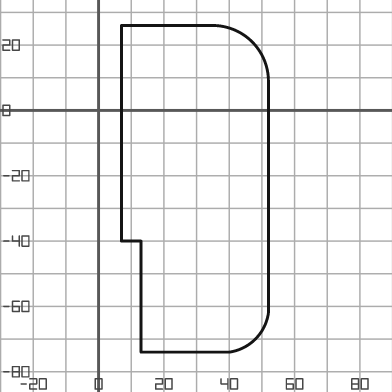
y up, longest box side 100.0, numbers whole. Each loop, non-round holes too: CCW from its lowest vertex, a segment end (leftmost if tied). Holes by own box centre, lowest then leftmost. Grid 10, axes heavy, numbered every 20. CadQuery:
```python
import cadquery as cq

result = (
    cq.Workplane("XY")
    .moveTo(13.0, -74.0)
    .lineTo(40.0, -74.0)
    .threePointArc((48.0, -70.0), (52.0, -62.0))
    .lineTo(52.0, 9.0)
    .threePointArc((47.0, 21.0), (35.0, 26.0))
    .lineTo(7.0, 26.0)
    .lineTo(7.0, -40.0)
    .lineTo(13.0, -40.0)
    .close()
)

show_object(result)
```